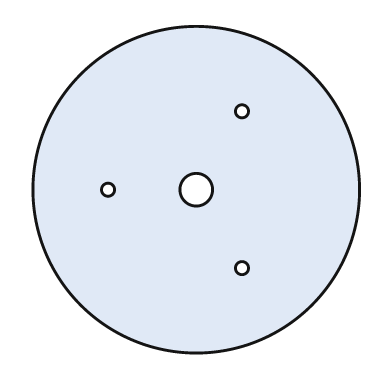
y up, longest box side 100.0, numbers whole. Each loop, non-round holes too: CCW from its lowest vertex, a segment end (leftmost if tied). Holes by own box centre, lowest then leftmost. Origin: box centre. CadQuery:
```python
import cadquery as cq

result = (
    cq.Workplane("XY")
    .moveTo(0.0, 0.0)
    .circle(50.0)
    .moveTo(14.0, -24.0)
    .circle(2.0)
    .moveTo(-27.0, 0.0)
    .circle(2.0)
    .moveTo(0.0, 0.0)
    .circle(5.0)
    .moveTo(14.0, 24.0)
    .circle(2.0)
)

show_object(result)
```